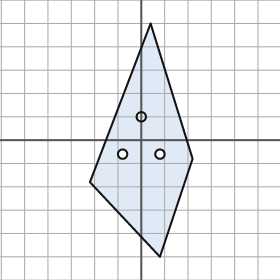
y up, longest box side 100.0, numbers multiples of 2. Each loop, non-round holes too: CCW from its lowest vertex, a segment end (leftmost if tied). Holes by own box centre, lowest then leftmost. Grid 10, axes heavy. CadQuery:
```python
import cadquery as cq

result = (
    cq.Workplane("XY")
    .moveTo(8.0, -50.0)
    .lineTo(22.0, -8.0)
    .lineTo(4.0, 50.0)
    .lineTo(-22.0, -18.0)
    .close()
    .moveTo(-8.0, -6.0)
    .circle(2.0)
    .moveTo(8.0, -6.0)
    .circle(2.0)
    .moveTo(0.0, 10.0)
    .circle(2.0)
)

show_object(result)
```